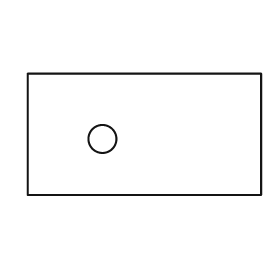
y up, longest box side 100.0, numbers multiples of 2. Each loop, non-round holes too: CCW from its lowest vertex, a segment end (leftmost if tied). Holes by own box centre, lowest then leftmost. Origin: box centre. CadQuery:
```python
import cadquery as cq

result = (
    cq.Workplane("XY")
    .moveTo(-50.0, -26.0)
    .lineTo(50.0, -26.0)
    .lineTo(50.0, 26.0)
    .lineTo(-50.0, 26.0)
    .close()
    .moveTo(-18.0, -2.0)
    .circle(6.0)
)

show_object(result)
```